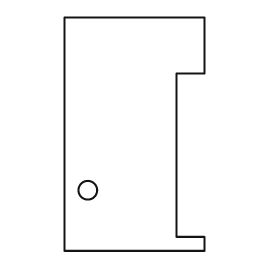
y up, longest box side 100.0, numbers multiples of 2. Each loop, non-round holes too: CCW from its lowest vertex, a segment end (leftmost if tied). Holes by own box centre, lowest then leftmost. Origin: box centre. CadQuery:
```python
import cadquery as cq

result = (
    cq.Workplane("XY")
    .moveTo(-30.0, -50.0)
    .lineTo(30.0, -50.0)
    .lineTo(30.0, -44.0)
    .lineTo(18.0, -44.0)
    .lineTo(18.0, 26.0)
    .lineTo(30.0, 26.0)
    .lineTo(30.0, 50.0)
    .lineTo(-30.0, 50.0)
    .close()
    .moveTo(-20.0, -24.0)
    .circle(4.0)
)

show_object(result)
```